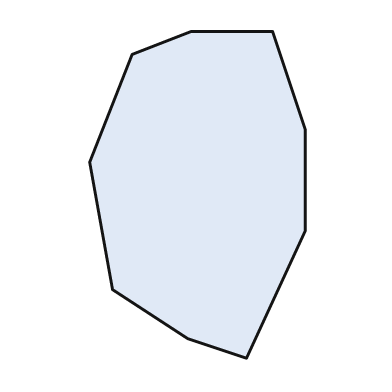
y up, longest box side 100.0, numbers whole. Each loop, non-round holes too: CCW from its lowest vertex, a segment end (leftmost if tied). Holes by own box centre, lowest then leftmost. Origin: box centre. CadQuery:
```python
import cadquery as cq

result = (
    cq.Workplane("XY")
    .moveTo(15.0, -50.0)
    .lineTo(33.0, -11.0)
    .lineTo(33.0, 20.0)
    .lineTo(23.0, 50.0)
    .lineTo(-2.0, 50.0)
    .lineTo(-20.0, 43.0)
    .lineTo(-33.0, 10.0)
    .lineTo(-26.0, -29.0)
    .lineTo(-3.0, -44.0)
    .close()
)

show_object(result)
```